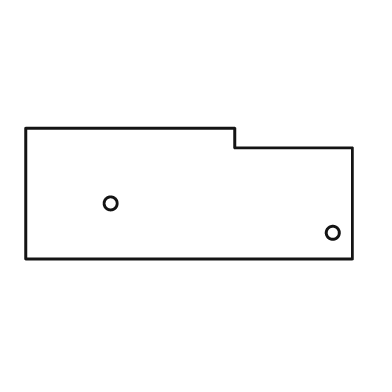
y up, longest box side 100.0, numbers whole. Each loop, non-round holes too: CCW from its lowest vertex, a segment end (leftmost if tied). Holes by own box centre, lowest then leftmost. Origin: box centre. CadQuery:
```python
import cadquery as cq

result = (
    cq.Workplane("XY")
    .moveTo(-50.0, -20.0)
    .lineTo(50.0, -20.0)
    .lineTo(50.0, 14.0)
    .lineTo(14.0, 14.0)
    .lineTo(14.0, 20.0)
    .lineTo(-50.0, 20.0)
    .close()
    .moveTo(44.0, -12.0)
    .circle(2.0)
    .moveTo(-24.0, -3.0)
    .circle(2.0)
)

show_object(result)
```